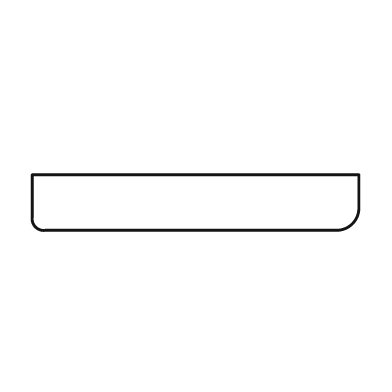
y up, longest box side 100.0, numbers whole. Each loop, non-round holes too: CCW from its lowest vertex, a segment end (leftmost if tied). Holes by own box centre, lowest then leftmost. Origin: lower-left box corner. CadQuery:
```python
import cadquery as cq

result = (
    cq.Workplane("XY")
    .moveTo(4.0, 0.0)
    .lineTo(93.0, 0.0)
    .threePointArc((98.0, 2.0), (100.0, 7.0))
    .lineTo(100.0, 17.0)
    .lineTo(0.0, 17.0)
    .lineTo(0.0, 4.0)
    .threePointArc((1.0, 1.0), (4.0, 0.0))
    .close()
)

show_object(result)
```